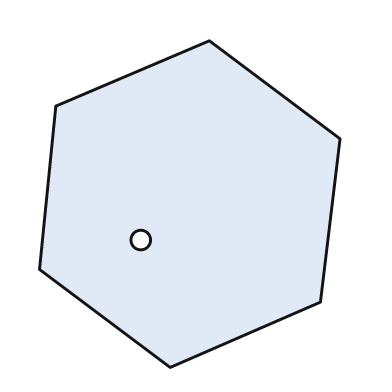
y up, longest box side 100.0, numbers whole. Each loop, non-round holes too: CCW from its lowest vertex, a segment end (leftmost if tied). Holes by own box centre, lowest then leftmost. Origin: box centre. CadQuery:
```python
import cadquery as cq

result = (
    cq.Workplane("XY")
    .moveTo(-6.0, -50.0)
    .lineTo(40.0, -30.0)
    .lineTo(46.0, 20.0)
    .lineTo(6.0, 50.0)
    .lineTo(-41.0, 30.0)
    .lineTo(-46.0, -20.0)
    .close()
    .moveTo(-15.0, -11.0)
    .circle(3.0)
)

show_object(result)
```